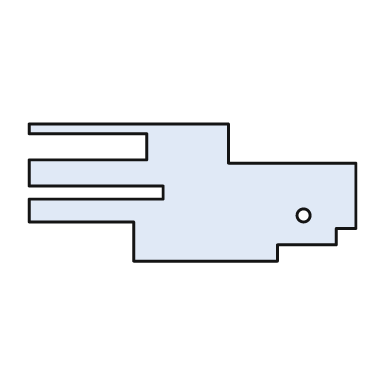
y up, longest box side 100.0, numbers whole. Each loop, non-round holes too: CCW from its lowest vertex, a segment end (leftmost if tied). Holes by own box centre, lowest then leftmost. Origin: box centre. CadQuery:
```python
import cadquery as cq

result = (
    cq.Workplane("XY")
    .moveTo(-18.0, -21.0)
    .lineTo(26.0, -21.0)
    .lineTo(26.0, -16.0)
    .lineTo(44.0, -16.0)
    .lineTo(44.0, -11.0)
    .lineTo(50.0, -11.0)
    .lineTo(50.0, 9.0)
    .lineTo(11.0, 9.0)
    .lineTo(11.0, 21.0)
    .lineTo(-50.0, 21.0)
    .lineTo(-50.0, 18.0)
    .lineTo(-14.0, 18.0)
    .lineTo(-14.0, 10.0)
    .lineTo(-50.0, 10.0)
    .lineTo(-50.0, 2.0)
    .lineTo(-9.0, 2.0)
    .lineTo(-9.0, -2.0)
    .lineTo(-50.0, -2.0)
    .lineTo(-50.0, -9.0)
    .lineTo(-18.0, -9.0)
    .close()
    .moveTo(34.0, -7.0)
    .circle(2.0)
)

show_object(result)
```